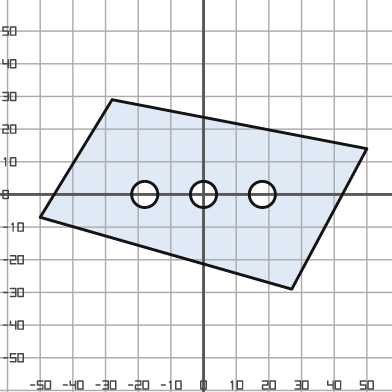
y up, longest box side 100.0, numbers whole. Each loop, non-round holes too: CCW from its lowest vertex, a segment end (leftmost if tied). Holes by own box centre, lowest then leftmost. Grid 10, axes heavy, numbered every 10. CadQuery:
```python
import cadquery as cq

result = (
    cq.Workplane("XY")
    .moveTo(27.0, -29.0)
    .lineTo(50.0, 14.0)
    .lineTo(-28.0, 29.0)
    .lineTo(-50.0, -7.0)
    .close()
    .moveTo(-18.0, 0.0)
    .circle(4.0)
    .moveTo(0.0, 0.0)
    .circle(4.0)
    .moveTo(18.0, 0.0)
    .circle(4.0)
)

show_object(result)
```